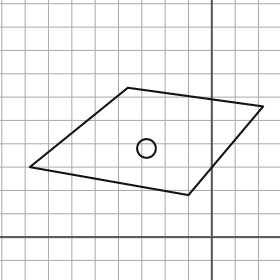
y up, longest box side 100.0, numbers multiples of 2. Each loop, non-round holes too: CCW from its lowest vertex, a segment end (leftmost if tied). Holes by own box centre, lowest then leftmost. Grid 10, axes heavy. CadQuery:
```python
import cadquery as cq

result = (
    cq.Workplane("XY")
    .moveTo(-10.0, 18.0)
    .lineTo(22.0, 56.0)
    .lineTo(-36.0, 64.0)
    .lineTo(-78.0, 30.0)
    .close()
    .moveTo(-28.0, 38.0)
    .circle(4.0)
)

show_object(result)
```